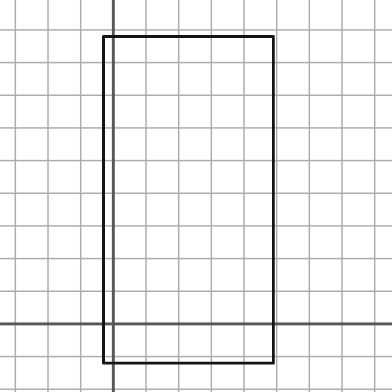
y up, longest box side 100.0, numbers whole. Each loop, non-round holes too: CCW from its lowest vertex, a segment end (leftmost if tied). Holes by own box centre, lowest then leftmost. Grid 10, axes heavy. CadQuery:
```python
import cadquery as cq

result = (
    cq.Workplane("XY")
    .moveTo(-3.0, -12.0)
    .lineTo(49.0, -12.0)
    .lineTo(49.0, 88.0)
    .lineTo(-3.0, 88.0)
    .close()
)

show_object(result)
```